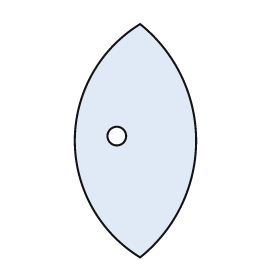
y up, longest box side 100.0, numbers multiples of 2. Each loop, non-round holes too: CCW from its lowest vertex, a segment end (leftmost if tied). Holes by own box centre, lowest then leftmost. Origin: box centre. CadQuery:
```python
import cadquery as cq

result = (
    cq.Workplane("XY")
    .moveTo(2.0, -50.0)
    .threePointArc((26.0, 0.0), (2.0, 50.0))
    .threePointArc((-26.0, 0.0), (2.0, -50.0))
    .close()
    .moveTo(-8.0, 2.0)
    .circle(4.0)
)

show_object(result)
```